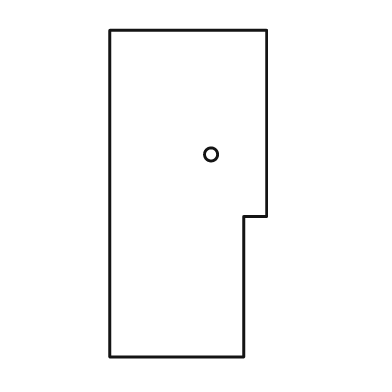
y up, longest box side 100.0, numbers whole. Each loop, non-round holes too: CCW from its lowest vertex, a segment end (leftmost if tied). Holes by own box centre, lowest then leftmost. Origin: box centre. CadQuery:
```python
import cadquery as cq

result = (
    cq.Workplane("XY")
    .moveTo(-24.0, -50.0)
    .lineTo(17.0, -50.0)
    .lineTo(17.0, -7.0)
    .lineTo(24.0, -7.0)
    .lineTo(24.0, 50.0)
    .lineTo(-24.0, 50.0)
    .close()
    .moveTo(7.0, 12.0)
    .circle(2.0)
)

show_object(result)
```